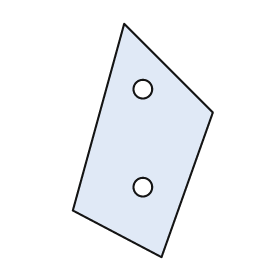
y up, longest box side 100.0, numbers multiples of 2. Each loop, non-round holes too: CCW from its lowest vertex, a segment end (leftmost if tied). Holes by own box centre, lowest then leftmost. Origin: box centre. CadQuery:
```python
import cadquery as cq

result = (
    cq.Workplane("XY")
    .moveTo(8.0, -50.0)
    .lineTo(30.0, 12.0)
    .lineTo(-8.0, 50.0)
    .lineTo(-30.0, -30.0)
    .close()
    .moveTo(0.0, -20.0)
    .circle(4.0)
    .moveTo(0.0, 22.0)
    .circle(4.0)
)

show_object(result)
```